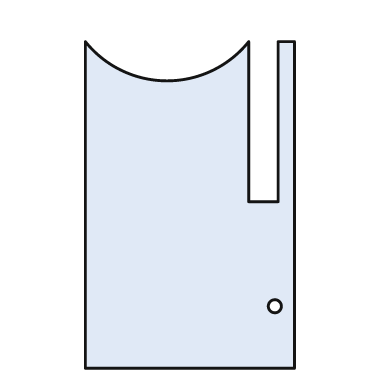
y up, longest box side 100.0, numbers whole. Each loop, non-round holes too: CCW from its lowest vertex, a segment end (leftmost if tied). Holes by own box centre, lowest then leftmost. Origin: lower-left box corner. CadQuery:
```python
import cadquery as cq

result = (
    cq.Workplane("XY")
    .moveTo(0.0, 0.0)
    .lineTo(64.0, 0.0)
    .lineTo(64.0, 100.0)
    .lineTo(59.0, 100.0)
    .lineTo(59.0, 51.0)
    .lineTo(50.0, 51.0)
    .lineTo(50.0, 100.0)
    .threePointArc((25.0, 88.0), (0.0, 100.0))
    .close()
    .moveTo(58.0, 19.0)
    .circle(2.0)
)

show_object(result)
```